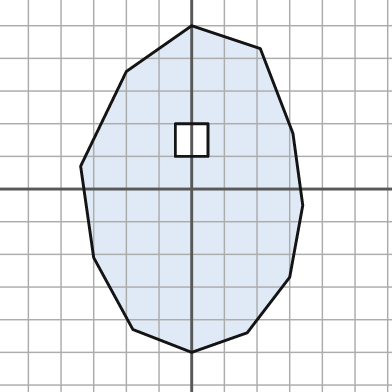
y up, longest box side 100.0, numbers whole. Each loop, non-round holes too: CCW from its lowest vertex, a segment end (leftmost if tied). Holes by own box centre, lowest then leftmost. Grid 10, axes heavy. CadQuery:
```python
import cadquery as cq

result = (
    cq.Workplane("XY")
    .moveTo(0.0, -50.0)
    .lineTo(17.0, -44.0)
    .lineTo(30.0, -27.0)
    .lineTo(34.0, -5.0)
    .lineTo(31.0, 17.0)
    .lineTo(21.0, 43.0)
    .lineTo(0.0, 50.0)
    .lineTo(-20.0, 36.0)
    .lineTo(-34.0, 7.0)
    .lineTo(-30.0, -21.0)
    .lineTo(-18.0, -43.0)
    .close()
    .moveTo(-5.0, 10.0)
    .lineTo(5.0, 10.0)
    .lineTo(5.0, 20.0)
    .lineTo(-5.0, 20.0)
    .close()
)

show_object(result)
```